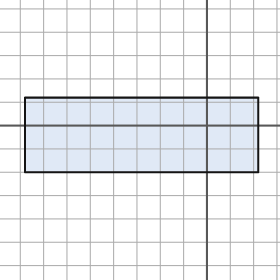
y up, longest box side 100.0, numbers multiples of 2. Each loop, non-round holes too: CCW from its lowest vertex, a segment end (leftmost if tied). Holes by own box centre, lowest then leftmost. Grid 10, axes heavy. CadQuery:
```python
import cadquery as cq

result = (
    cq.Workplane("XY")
    .moveTo(-78.0, -20.0)
    .lineTo(22.0, -20.0)
    .lineTo(22.0, 12.0)
    .lineTo(-78.0, 12.0)
    .close()
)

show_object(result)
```